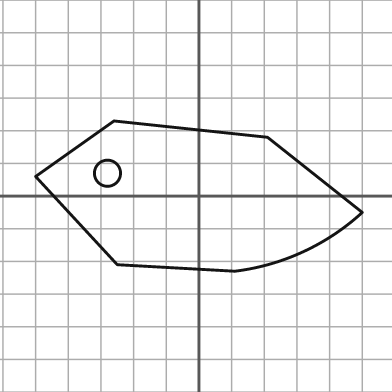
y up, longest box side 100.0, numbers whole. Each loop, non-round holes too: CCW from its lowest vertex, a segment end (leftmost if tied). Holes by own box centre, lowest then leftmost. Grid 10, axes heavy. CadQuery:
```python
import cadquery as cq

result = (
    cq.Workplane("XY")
    .moveTo(11.0, -23.0)
    .threePointArc((32.0, -17.0), (50.0, -5.0))
    .lineTo(21.0, 18.0)
    .lineTo(-26.0, 23.0)
    .lineTo(-50.0, 6.0)
    .lineTo(-25.0, -21.0)
    .close()
    .moveTo(-28.0, 7.0)
    .circle(4.0)
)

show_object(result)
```